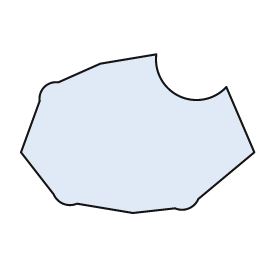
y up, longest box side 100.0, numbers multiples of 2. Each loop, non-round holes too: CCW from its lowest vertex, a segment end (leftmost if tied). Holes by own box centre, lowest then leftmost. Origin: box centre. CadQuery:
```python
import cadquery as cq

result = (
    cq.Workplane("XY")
    .moveTo(-2.0, -34.0)
    .lineTo(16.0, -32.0)
    .threePointArc((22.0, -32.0), (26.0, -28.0))
    .lineTo(50.0, -8.0)
    .lineTo(38.0, 20.0)
    .threePointArc((18.0, 16.0), (8.0, 34.0))
    .lineTo(-16.0, 30.0)
    .lineTo(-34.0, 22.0)
    .threePointArc((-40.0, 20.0), (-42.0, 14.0))
    .lineTo(-50.0, -8.0)
    .lineTo(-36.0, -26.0)
    .threePointArc((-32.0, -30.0), (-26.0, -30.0))
    .close()
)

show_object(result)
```